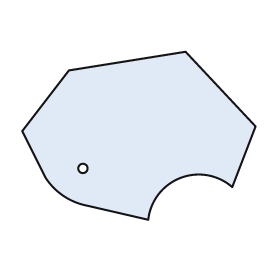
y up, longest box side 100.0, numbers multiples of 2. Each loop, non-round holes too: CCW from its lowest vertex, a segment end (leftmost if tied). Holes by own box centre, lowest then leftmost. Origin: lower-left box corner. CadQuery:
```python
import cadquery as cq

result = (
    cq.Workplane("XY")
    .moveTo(54.0, 0.0)
    .threePointArc((68.0, 18.0), (90.0, 14.0))
    .lineTo(100.0, 40.0)
    .lineTo(70.0, 72.0)
    .lineTo(20.0, 64.0)
    .lineTo(0.0, 38.0)
    .lineTo(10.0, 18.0)
    .threePointArc((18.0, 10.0), (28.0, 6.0))
    .close()
    .moveTo(26.0, 22.0)
    .circle(2.0)
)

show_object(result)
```